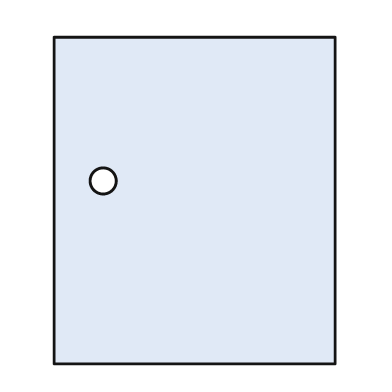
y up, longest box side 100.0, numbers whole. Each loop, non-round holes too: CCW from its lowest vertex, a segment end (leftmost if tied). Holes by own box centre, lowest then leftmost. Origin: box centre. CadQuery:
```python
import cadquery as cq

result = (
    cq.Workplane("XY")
    .moveTo(-43.0, -50.0)
    .lineTo(43.0, -50.0)
    .lineTo(43.0, 50.0)
    .lineTo(-43.0, 50.0)
    .close()
    .moveTo(-28.0, 6.0)
    .circle(4.0)
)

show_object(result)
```